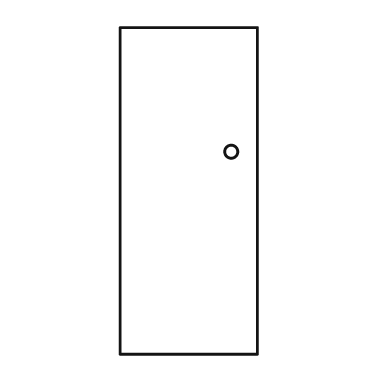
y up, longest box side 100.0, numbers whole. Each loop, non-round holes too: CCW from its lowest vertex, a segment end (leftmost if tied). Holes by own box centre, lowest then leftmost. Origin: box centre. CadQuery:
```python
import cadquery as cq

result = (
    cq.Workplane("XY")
    .moveTo(-21.0, -50.0)
    .lineTo(21.0, -50.0)
    .lineTo(21.0, 50.0)
    .lineTo(-21.0, 50.0)
    .close()
    .moveTo(13.0, 12.0)
    .circle(2.0)
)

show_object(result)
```